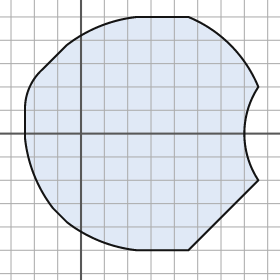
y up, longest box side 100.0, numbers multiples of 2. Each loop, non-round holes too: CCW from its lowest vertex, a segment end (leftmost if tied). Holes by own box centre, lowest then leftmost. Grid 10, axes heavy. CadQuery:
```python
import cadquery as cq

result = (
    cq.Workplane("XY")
    .moveTo(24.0, -50.0)
    .lineTo(46.0, -50.0)
    .lineTo(76.0, -20.0)
    .threePointArc((70.0, 0.0), (76.0, 20.0))
    .threePointArc((64.0, 38.0), (46.0, 50.0))
    .lineTo(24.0, 50.0)
    .threePointArc((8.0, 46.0), (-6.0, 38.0))
    .lineTo(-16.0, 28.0)
    .threePointArc((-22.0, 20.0), (-24.0, 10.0))
    .lineTo(-24.0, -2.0)
    .threePointArc((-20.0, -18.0), (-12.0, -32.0))
    .lineTo(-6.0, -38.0)
    .threePointArc((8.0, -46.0), (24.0, -50.0))
    .close()
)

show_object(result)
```